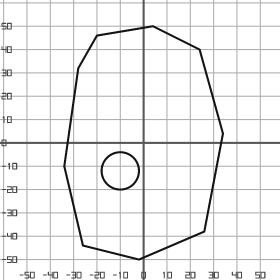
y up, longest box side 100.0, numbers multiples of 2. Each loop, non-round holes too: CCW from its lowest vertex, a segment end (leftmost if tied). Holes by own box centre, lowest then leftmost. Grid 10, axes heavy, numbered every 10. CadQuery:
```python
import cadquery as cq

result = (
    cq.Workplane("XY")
    .moveTo(-2.0, -50.0)
    .lineTo(26.0, -38.0)
    .lineTo(34.0, 4.0)
    .lineTo(24.0, 40.0)
    .lineTo(4.0, 50.0)
    .lineTo(-20.0, 46.0)
    .lineTo(-28.0, 32.0)
    .lineTo(-34.0, -10.0)
    .lineTo(-26.0, -44.0)
    .close()
    .moveTo(-10.0, -12.0)
    .circle(8.0)
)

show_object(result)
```